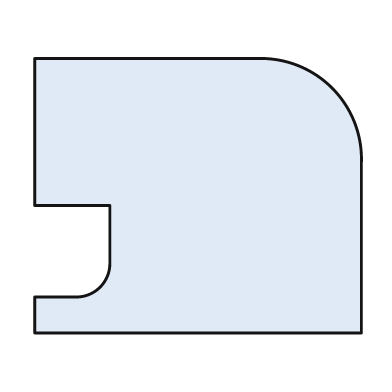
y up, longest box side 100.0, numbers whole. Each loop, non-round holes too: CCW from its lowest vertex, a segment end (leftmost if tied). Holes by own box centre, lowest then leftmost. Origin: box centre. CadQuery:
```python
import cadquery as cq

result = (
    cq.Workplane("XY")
    .moveTo(-50.0, -42.0)
    .lineTo(50.0, -42.0)
    .lineTo(50.0, 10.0)
    .threePointArc((41.0, 33.0), (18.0, 42.0))
    .lineTo(-50.0, 42.0)
    .lineTo(-50.0, -3.0)
    .lineTo(-27.0, -3.0)
    .lineTo(-27.0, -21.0)
    .threePointArc((-30.0, -28.0), (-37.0, -31.0))
    .lineTo(-50.0, -31.0)
    .close()
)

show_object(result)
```